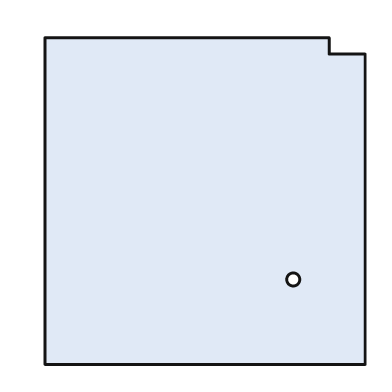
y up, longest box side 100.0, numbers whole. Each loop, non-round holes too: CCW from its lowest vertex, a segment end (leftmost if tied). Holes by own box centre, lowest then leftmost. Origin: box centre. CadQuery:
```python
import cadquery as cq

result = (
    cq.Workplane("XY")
    .moveTo(-49.0, -50.0)
    .lineTo(49.0, -50.0)
    .lineTo(49.0, 45.0)
    .lineTo(38.0, 45.0)
    .lineTo(38.0, 50.0)
    .lineTo(-49.0, 50.0)
    .close()
    .moveTo(27.0, -24.0)
    .circle(2.0)
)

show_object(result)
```